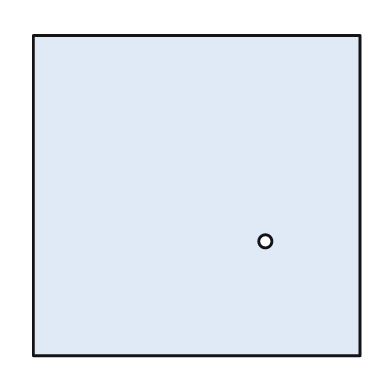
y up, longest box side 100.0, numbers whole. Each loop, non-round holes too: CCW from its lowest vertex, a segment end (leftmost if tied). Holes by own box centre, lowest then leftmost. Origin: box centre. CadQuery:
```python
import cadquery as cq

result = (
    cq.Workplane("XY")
    .moveTo(-50.0, -49.0)
    .lineTo(50.0, -49.0)
    .lineTo(50.0, 49.0)
    .lineTo(-50.0, 49.0)
    .close()
    .moveTo(21.0, -14.0)
    .circle(2.0)
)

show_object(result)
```